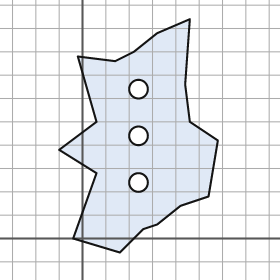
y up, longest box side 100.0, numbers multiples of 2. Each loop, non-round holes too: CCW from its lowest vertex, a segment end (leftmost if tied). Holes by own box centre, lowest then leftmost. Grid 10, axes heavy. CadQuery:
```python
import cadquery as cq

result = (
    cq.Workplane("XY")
    .moveTo(16.0, -6.0)
    .lineTo(26.0, 4.0)
    .lineTo(32.0, 6.0)
    .lineTo(42.0, 14.0)
    .lineTo(54.0, 18.0)
    .lineTo(58.0, 42.0)
    .lineTo(46.0, 50.0)
    .lineTo(44.0, 66.0)
    .lineTo(46.0, 94.0)
    .lineTo(32.0, 88.0)
    .lineTo(22.0, 80.0)
    .lineTo(14.0, 76.0)
    .lineTo(-2.0, 78.0)
    .lineTo(6.0, 50.0)
    .lineTo(-10.0, 38.0)
    .lineTo(6.0, 28.0)
    .lineTo(-4.0, 0.0)
    .close()
    .moveTo(24.0, 24.0)
    .circle(4.0)
    .moveTo(24.0, 44.0)
    .circle(4.0)
    .moveTo(24.0, 64.0)
    .circle(4.0)
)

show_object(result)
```